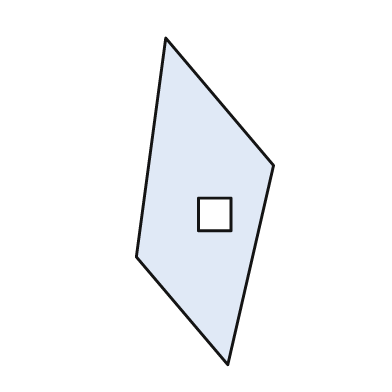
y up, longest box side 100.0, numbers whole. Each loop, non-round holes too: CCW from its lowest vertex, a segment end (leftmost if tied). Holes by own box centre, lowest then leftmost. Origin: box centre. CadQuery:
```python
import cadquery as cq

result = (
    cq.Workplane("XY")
    .moveTo(7.0, -50.0)
    .lineTo(21.0, 11.0)
    .lineTo(-12.0, 50.0)
    .lineTo(-21.0, -17.0)
    .close()
    .moveTo(-2.0, -9.0)
    .lineTo(8.0, -9.0)
    .lineTo(8.0, 1.0)
    .lineTo(-2.0, 1.0)
    .close()
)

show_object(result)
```